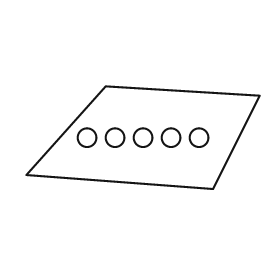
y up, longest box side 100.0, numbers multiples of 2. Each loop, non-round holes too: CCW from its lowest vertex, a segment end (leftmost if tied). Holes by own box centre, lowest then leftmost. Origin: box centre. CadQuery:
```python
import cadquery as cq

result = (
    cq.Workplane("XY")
    .moveTo(30.0, -22.0)
    .lineTo(50.0, 18.0)
    .lineTo(-16.0, 22.0)
    .lineTo(-50.0, -16.0)
    .close()
    .moveTo(-24.0, 0.0)
    .circle(4.0)
    .moveTo(-12.0, 0.0)
    .circle(4.0)
    .moveTo(0.0, 0.0)
    .circle(4.0)
    .moveTo(12.0, 0.0)
    .circle(4.0)
    .moveTo(24.0, 0.0)
    .circle(4.0)
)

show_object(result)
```